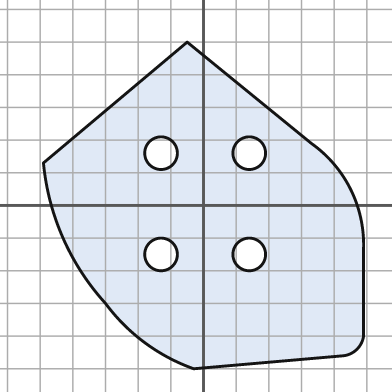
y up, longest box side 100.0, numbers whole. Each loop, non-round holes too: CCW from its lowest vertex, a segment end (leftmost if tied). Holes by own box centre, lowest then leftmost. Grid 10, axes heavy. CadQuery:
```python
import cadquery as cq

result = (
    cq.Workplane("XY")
    .moveTo(-3.0, -50.0)
    .lineTo(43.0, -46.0)
    .threePointArc((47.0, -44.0), (49.0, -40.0))
    .lineTo(49.0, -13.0)
    .threePointArc((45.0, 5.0), (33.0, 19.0))
    .lineTo(-5.0, 50.0)
    .lineTo(-49.0, 13.0)
    .threePointArc((-43.0, -10.0), (-30.0, -30.0))
    .threePointArc((-18.0, -42.0), (-3.0, -50.0))
    .close()
    .moveTo(-13.0, -15.0)
    .circle(5.0)
    .moveTo(14.0, -15.0)
    .circle(5.0)
    .moveTo(-13.0, 16.0)
    .circle(5.0)
    .moveTo(14.0, 16.0)
    .circle(5.0)
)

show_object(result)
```